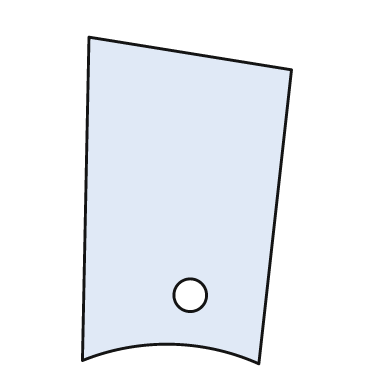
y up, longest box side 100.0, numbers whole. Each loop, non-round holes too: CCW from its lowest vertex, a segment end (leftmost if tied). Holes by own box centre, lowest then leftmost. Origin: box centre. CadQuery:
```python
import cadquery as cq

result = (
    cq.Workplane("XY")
    .moveTo(22.0, -50.0)
    .lineTo(32.0, 40.0)
    .lineTo(-30.0, 50.0)
    .lineTo(-32.0, -49.0)
    .threePointArc((-5.0, -44.0), (22.0, -50.0))
    .close()
    .moveTo(1.0, -29.0)
    .circle(5.0)
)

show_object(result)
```